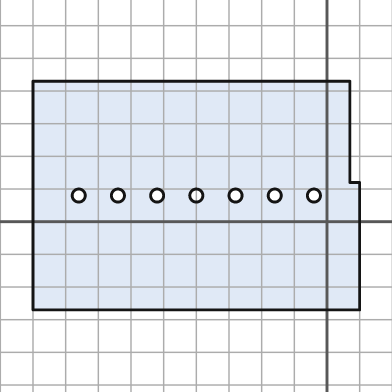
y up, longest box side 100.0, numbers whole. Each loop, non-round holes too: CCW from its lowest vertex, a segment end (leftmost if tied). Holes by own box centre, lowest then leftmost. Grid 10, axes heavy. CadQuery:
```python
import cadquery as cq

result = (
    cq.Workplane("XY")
    .moveTo(-90.0, -27.0)
    .lineTo(10.0, -27.0)
    .lineTo(10.0, 12.0)
    .lineTo(7.0, 12.0)
    .lineTo(7.0, 43.0)
    .lineTo(-90.0, 43.0)
    .close()
    .moveTo(-76.0, 8.0)
    .circle(2.0)
    .moveTo(-64.0, 8.0)
    .circle(2.0)
    .moveTo(-52.0, 8.0)
    .circle(2.0)
    .moveTo(-40.0, 8.0)
    .circle(2.0)
    .moveTo(-28.0, 8.0)
    .circle(2.0)
    .moveTo(-16.0, 8.0)
    .circle(2.0)
    .moveTo(-4.0, 8.0)
    .circle(2.0)
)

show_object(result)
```